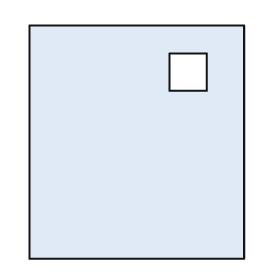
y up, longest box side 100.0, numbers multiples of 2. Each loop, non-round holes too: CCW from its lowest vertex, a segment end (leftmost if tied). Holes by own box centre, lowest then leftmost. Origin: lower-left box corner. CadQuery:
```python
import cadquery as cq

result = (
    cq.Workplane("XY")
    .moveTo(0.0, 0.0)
    .lineTo(92.0, 0.0)
    .lineTo(92.0, 100.0)
    .lineTo(0.0, 100.0)
    .close()
    .moveTo(60.0, 72.0)
    .lineTo(76.0, 72.0)
    .lineTo(76.0, 88.0)
    .lineTo(60.0, 88.0)
    .close()
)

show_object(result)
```